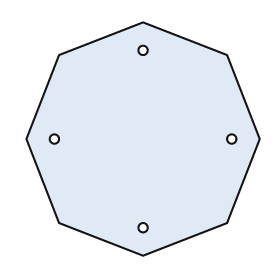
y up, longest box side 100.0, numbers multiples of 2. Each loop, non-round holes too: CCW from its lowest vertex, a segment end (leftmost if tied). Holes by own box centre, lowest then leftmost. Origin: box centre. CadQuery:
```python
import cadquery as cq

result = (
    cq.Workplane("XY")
    .moveTo(0.0, -50.0)
    .lineTo(36.0, -36.0)
    .lineTo(50.0, 0.0)
    .lineTo(36.0, 36.0)
    .lineTo(0.0, 50.0)
    .lineTo(-36.0, 36.0)
    .lineTo(-50.0, 0.0)
    .lineTo(-36.0, -36.0)
    .close()
    .moveTo(0.0, -38.0)
    .circle(2.0)
    .moveTo(-38.0, 0.0)
    .circle(2.0)
    .moveTo(38.0, 0.0)
    .circle(2.0)
    .moveTo(0.0, 38.0)
    .circle(2.0)
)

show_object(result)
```